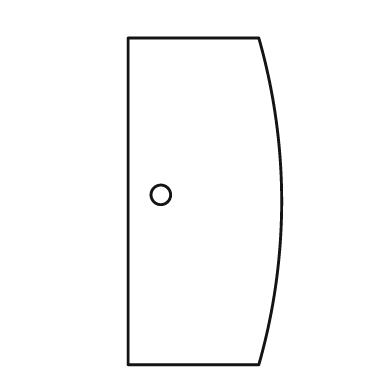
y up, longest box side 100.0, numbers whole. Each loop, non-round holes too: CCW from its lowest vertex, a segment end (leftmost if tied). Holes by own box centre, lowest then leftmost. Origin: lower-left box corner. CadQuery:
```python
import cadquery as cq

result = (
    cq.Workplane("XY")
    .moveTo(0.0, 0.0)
    .lineTo(40.0, 0.0)
    .threePointArc((47.0, 50.0), (40.0, 100.0))
    .lineTo(0.0, 100.0)
    .close()
    .moveTo(10.0, 52.0)
    .circle(3.0)
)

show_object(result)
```